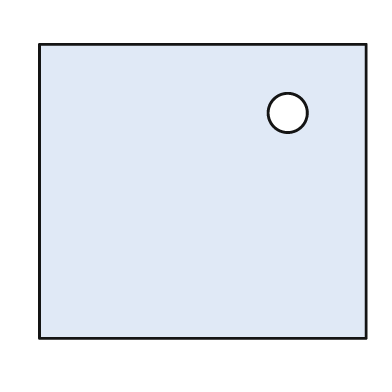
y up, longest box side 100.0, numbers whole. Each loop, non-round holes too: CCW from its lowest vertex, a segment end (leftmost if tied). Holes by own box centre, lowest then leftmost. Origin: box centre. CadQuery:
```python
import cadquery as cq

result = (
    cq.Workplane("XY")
    .moveTo(-50.0, -45.0)
    .lineTo(50.0, -45.0)
    .lineTo(50.0, 45.0)
    .lineTo(-50.0, 45.0)
    .close()
    .moveTo(26.0, 24.0)
    .circle(6.0)
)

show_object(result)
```